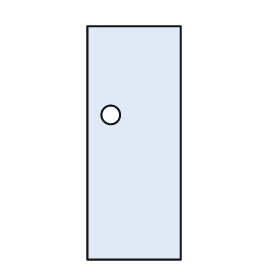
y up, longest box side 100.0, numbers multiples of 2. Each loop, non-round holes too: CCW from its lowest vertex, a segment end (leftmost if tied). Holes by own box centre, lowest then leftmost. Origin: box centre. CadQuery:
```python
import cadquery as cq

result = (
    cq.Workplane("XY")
    .moveTo(-20.0, -50.0)
    .lineTo(20.0, -50.0)
    .lineTo(20.0, 50.0)
    .lineTo(-20.0, 50.0)
    .close()
    .moveTo(-10.0, 12.0)
    .circle(4.0)
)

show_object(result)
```